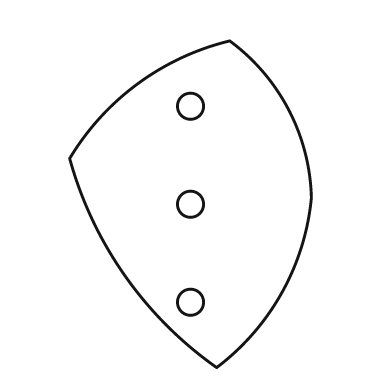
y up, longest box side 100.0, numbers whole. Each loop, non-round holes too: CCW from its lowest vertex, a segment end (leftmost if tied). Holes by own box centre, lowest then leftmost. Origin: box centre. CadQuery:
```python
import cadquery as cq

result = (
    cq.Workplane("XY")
    .moveTo(8.0, -50.0)
    .threePointArc((28.0, -27.0), (37.0, 2.0))
    .threePointArc((30.0, 29.0), (12.0, 50.0))
    .threePointArc((-16.0, 37.0), (-37.0, 14.0))
    .threePointArc((-20.0, -22.0), (8.0, -50.0))
    .close()
    .moveTo(0.0, -30.0)
    .circle(4.0)
    .moveTo(0.0, 0.0)
    .circle(4.0)
    .moveTo(0.0, 30.0)
    .circle(4.0)
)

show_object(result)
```